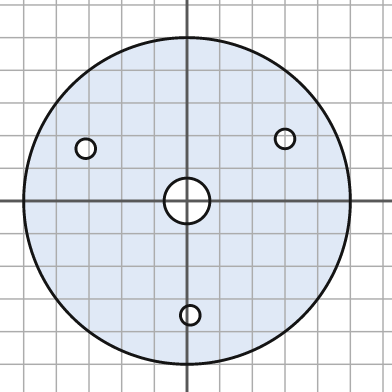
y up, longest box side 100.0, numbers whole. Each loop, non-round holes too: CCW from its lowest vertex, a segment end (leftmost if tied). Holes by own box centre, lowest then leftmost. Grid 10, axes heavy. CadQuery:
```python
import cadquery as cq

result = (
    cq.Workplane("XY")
    .moveTo(0.0, 0.0)
    .circle(50.0)
    .moveTo(1.0, -35.0)
    .circle(3.0)
    .moveTo(0.0, 0.0)
    .circle(7.0)
    .moveTo(-31.0, 16.0)
    .circle(3.0)
    .moveTo(30.0, 19.0)
    .circle(3.0)
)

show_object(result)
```